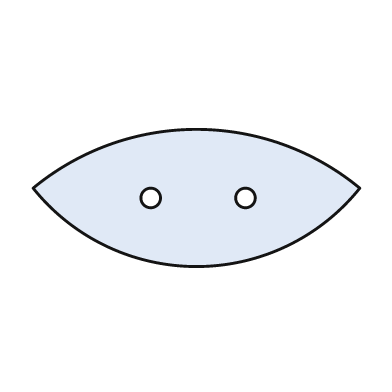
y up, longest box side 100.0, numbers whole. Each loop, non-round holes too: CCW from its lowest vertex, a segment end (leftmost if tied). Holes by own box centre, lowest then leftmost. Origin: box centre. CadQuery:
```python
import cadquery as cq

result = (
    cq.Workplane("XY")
    .moveTo(-50.0, 3.0)
    .threePointArc((0.0, -21.0), (50.0, 3.0))
    .threePointArc((0.0, 21.0), (-50.0, 3.0))
    .close()
    .moveTo(-14.0, 0.0)
    .circle(3.0)
    .moveTo(15.0, 0.0)
    .circle(3.0)
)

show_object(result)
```